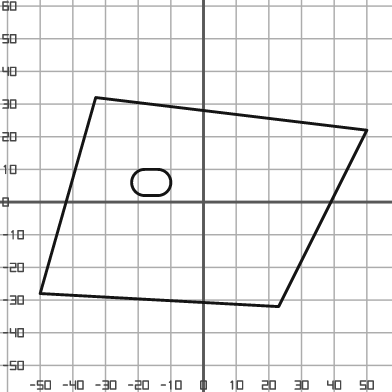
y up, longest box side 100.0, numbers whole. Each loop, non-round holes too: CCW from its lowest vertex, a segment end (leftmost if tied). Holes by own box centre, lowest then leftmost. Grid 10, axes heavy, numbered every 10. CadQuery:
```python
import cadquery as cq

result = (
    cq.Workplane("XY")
    .moveTo(23.0, -32.0)
    .lineTo(50.0, 22.0)
    .lineTo(-33.0, 32.0)
    .lineTo(-50.0, -28.0)
    .close()
    .moveTo(-18.0, 2.0)
    .lineTo(-14.0, 2.0)
    .threePointArc((-10.0, 6.0), (-14.0, 10.0))
    .lineTo(-18.0, 10.0)
    .threePointArc((-22.0, 6.0), (-18.0, 2.0))
    .close()
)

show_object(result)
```